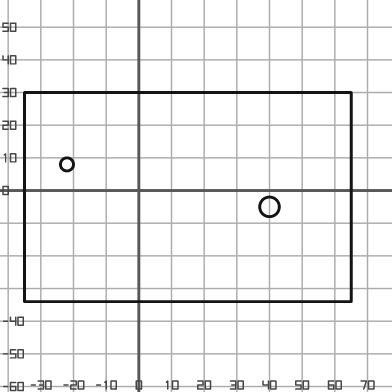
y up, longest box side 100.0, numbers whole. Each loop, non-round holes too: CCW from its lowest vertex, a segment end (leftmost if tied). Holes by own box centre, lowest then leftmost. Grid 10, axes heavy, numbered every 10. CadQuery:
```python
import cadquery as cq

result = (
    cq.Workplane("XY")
    .moveTo(-35.0, -34.0)
    .lineTo(65.0, -34.0)
    .lineTo(65.0, 30.0)
    .lineTo(-35.0, 30.0)
    .close()
    .moveTo(40.0, -5.0)
    .circle(3.0)
    .moveTo(-22.0, 8.0)
    .circle(2.0)
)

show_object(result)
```